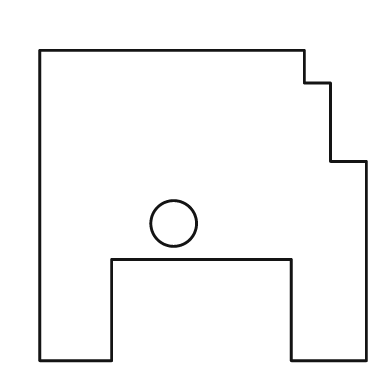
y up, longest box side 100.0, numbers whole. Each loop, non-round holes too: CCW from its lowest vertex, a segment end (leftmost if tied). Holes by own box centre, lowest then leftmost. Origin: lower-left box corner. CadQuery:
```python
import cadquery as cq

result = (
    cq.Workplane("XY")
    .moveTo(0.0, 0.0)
    .lineTo(22.0, 0.0)
    .lineTo(22.0, 31.0)
    .lineTo(77.0, 31.0)
    .lineTo(77.0, 0.0)
    .lineTo(100.0, 0.0)
    .lineTo(100.0, 61.0)
    .lineTo(89.0, 61.0)
    .lineTo(89.0, 85.0)
    .lineTo(81.0, 85.0)
    .lineTo(81.0, 95.0)
    .lineTo(0.0, 95.0)
    .close()
    .moveTo(41.0, 42.0)
    .circle(7.0)
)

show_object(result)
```